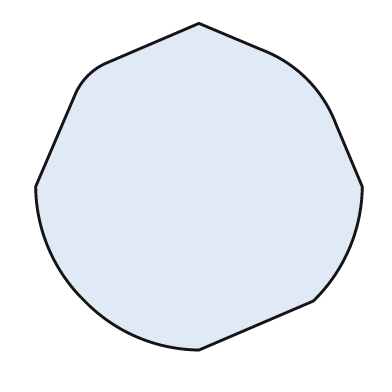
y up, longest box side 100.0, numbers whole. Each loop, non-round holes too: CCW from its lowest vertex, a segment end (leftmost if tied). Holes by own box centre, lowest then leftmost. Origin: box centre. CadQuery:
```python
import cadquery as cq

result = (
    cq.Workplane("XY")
    .moveTo(0.0, -50.0)
    .lineTo(35.0, -35.0)
    .threePointArc((46.0, -19.0), (50.0, 0.0))
    .lineTo(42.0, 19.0)
    .threePointArc((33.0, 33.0), (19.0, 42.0))
    .lineTo(0.0, 50.0)
    .lineTo(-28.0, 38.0)
    .threePointArc((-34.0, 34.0), (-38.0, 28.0))
    .lineTo(-50.0, 0.0)
    .threePointArc((-46.0, -19.0), (-35.0, -35.0))
    .threePointArc((-19.0, -46.0), (0.0, -50.0))
    .close()
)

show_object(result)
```